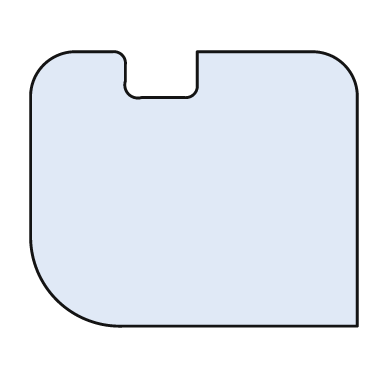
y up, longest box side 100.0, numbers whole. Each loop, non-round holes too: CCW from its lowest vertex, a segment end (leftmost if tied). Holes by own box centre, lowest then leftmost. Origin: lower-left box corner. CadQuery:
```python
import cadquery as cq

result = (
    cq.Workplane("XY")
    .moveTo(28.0, 0.0)
    .lineTo(100.0, 0.0)
    .lineTo(100.0, 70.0)
    .threePointArc((96.0, 80.0), (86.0, 84.0))
    .lineTo(51.0, 84.0)
    .lineTo(51.0, 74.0)
    .threePointArc((50.0, 71.0), (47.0, 70.0))
    .lineTo(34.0, 70.0)
    .threePointArc((30.0, 71.0), (29.0, 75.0))
    .lineTo(29.0, 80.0)
    .threePointArc((28.0, 83.0), (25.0, 84.0))
    .lineTo(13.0, 84.0)
    .threePointArc((4.0, 80.0), (0.0, 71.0))
    .lineTo(0.0, 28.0)
    .threePointArc((8.0, 8.0), (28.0, 0.0))
    .close()
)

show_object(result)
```